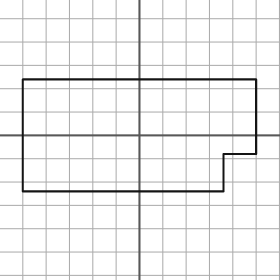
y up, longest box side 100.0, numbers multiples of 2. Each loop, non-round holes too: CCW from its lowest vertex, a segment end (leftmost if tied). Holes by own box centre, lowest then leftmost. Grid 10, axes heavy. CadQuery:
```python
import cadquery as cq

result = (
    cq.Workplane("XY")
    .moveTo(-50.0, -24.0)
    .lineTo(36.0, -24.0)
    .lineTo(36.0, -8.0)
    .lineTo(50.0, -8.0)
    .lineTo(50.0, 24.0)
    .lineTo(-50.0, 24.0)
    .close()
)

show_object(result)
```